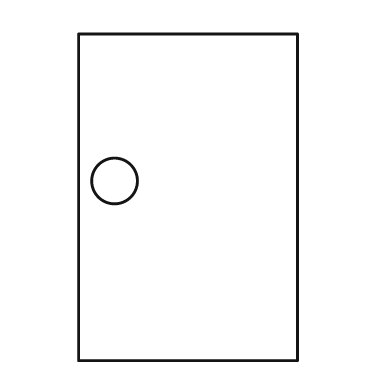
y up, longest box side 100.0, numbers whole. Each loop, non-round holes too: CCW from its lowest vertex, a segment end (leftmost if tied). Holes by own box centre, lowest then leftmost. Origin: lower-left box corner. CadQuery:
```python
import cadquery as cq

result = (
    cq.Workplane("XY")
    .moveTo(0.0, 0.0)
    .lineTo(67.0, 0.0)
    .lineTo(67.0, 100.0)
    .lineTo(0.0, 100.0)
    .close()
    .moveTo(11.0, 55.0)
    .circle(7.0)
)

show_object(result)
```